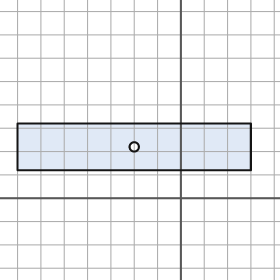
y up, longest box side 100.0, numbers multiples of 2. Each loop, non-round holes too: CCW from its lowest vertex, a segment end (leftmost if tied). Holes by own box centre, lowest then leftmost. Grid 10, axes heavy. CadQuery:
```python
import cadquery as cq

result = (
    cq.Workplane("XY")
    .moveTo(-70.0, 12.0)
    .lineTo(30.0, 12.0)
    .lineTo(30.0, 32.0)
    .lineTo(-70.0, 32.0)
    .close()
    .moveTo(-20.0, 22.0)
    .circle(2.0)
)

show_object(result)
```